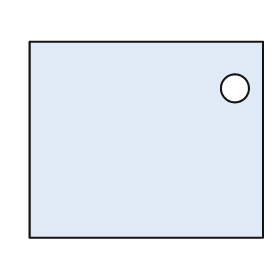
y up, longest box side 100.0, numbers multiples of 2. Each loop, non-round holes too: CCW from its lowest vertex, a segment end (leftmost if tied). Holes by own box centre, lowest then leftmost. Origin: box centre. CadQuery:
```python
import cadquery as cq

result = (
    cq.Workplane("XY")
    .moveTo(-50.0, -42.0)
    .lineTo(50.0, -42.0)
    .lineTo(50.0, 42.0)
    .lineTo(-50.0, 42.0)
    .close()
    .moveTo(38.0, 22.0)
    .circle(6.0)
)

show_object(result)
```